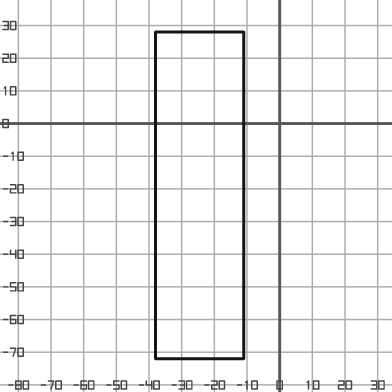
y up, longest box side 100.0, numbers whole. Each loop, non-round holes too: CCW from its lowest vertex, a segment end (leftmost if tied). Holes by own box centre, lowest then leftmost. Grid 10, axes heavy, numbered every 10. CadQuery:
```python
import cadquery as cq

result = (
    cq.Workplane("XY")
    .moveTo(-38.0, -72.0)
    .lineTo(-11.0, -72.0)
    .lineTo(-11.0, 28.0)
    .lineTo(-38.0, 28.0)
    .close()
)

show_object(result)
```